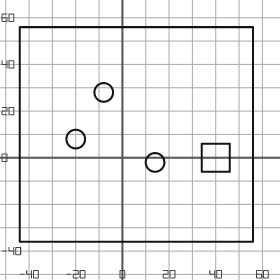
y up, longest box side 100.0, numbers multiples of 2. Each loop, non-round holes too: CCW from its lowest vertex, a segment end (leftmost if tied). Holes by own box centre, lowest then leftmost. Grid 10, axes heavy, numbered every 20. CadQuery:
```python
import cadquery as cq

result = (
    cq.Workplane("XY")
    .moveTo(-44.0, -36.0)
    .lineTo(56.0, -36.0)
    .lineTo(56.0, 56.0)
    .lineTo(-44.0, 56.0)
    .close()
    .moveTo(14.0, -2.0)
    .circle(4.0)
    .moveTo(34.0, -6.0)
    .lineTo(46.0, -6.0)
    .lineTo(46.0, 6.0)
    .lineTo(34.0, 6.0)
    .close()
    .moveTo(-20.0, 8.0)
    .circle(4.0)
    .moveTo(-8.0, 28.0)
    .circle(4.0)
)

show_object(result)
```